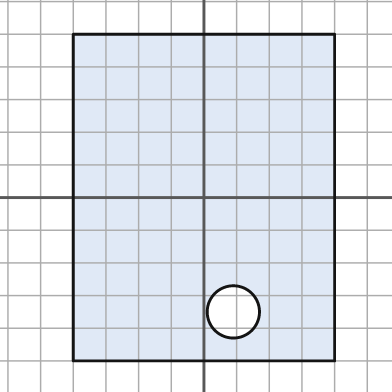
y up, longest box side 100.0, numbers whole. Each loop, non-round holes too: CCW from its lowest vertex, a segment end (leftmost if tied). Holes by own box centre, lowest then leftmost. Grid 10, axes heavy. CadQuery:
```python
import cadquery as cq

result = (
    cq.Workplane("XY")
    .moveTo(-40.0, -50.0)
    .lineTo(40.0, -50.0)
    .lineTo(40.0, 50.0)
    .lineTo(-40.0, 50.0)
    .close()
    .moveTo(9.0, -35.0)
    .circle(8.0)
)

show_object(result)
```